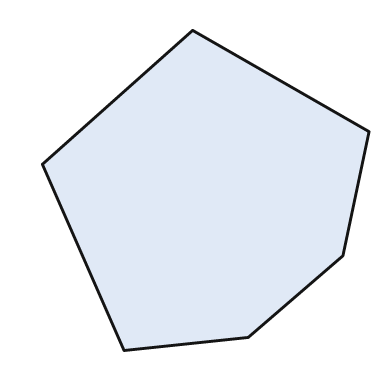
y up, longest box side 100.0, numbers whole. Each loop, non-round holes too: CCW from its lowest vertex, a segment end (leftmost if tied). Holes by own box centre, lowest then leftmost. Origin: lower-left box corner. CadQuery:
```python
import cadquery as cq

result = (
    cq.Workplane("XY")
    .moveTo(25.0, 0.0)
    .lineTo(63.0, 4.0)
    .lineTo(92.0, 29.0)
    .lineTo(100.0, 67.0)
    .lineTo(46.0, 98.0)
    .lineTo(0.0, 57.0)
    .close()
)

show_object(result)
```